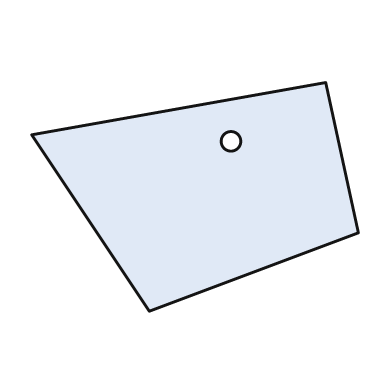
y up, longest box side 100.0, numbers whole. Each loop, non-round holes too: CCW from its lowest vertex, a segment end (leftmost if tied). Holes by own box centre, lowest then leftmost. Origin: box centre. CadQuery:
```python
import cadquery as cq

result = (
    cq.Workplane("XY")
    .moveTo(-14.0, -35.0)
    .lineTo(50.0, -11.0)
    .lineTo(40.0, 35.0)
    .lineTo(-50.0, 19.0)
    .close()
    .moveTo(11.0, 17.0)
    .circle(3.0)
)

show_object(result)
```